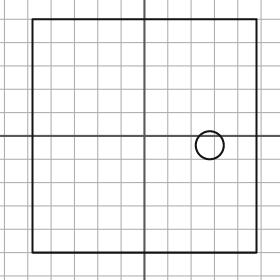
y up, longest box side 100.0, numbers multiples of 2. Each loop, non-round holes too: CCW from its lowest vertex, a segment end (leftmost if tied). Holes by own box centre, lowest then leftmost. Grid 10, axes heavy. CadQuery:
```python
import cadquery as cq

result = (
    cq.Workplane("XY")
    .moveTo(-48.0, -50.0)
    .lineTo(48.0, -50.0)
    .lineTo(48.0, 50.0)
    .lineTo(-48.0, 50.0)
    .close()
    .moveTo(28.0, -4.0)
    .circle(6.0)
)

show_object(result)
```